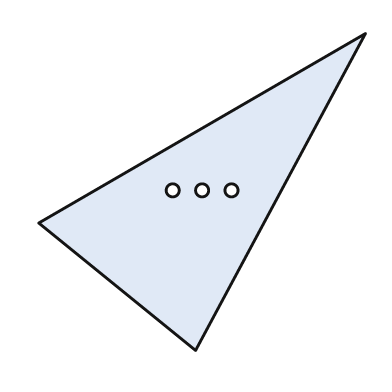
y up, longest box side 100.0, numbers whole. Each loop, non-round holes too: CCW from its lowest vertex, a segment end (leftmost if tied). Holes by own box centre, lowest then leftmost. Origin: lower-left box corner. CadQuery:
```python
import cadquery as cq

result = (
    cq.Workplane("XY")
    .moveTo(48.0, 0.0)
    .lineTo(100.0, 97.0)
    .lineTo(0.0, 39.0)
    .close()
    .moveTo(41.0, 49.0)
    .circle(2.0)
    .moveTo(50.0, 49.0)
    .circle(2.0)
    .moveTo(59.0, 49.0)
    .circle(2.0)
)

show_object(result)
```